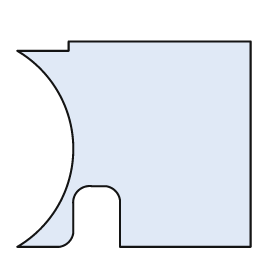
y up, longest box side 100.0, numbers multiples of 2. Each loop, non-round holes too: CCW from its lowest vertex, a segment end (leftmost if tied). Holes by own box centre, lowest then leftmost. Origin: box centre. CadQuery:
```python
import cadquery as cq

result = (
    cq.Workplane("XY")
    .moveTo(-50.0, -44.0)
    .lineTo(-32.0, -44.0)
    .threePointArc((-28.0, -42.0), (-26.0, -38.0))
    .lineTo(-26.0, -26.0)
    .threePointArc((-24.0, -20.0), (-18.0, -18.0))
    .lineTo(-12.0, -18.0)
    .threePointArc((-8.0, -20.0), (-6.0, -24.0))
    .lineTo(-6.0, -44.0)
    .lineTo(50.0, -44.0)
    .lineTo(50.0, 44.0)
    .lineTo(-28.0, 44.0)
    .lineTo(-28.0, 40.0)
    .lineTo(-50.0, 40.0)
    .threePointArc((-26.0, -2.0), (-50.0, -44.0))
    .close()
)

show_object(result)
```